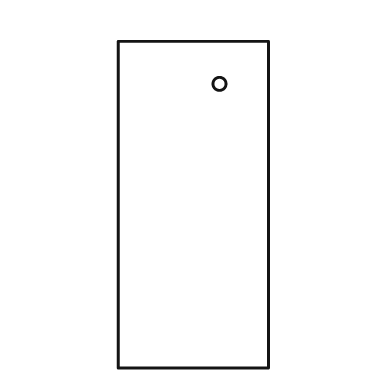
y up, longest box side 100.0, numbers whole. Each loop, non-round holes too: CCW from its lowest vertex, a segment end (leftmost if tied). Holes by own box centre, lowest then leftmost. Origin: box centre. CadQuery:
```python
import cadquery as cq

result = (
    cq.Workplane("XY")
    .moveTo(-23.0, -50.0)
    .lineTo(23.0, -50.0)
    .lineTo(23.0, 50.0)
    .lineTo(-23.0, 50.0)
    .close()
    .moveTo(8.0, 37.0)
    .circle(2.0)
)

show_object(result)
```